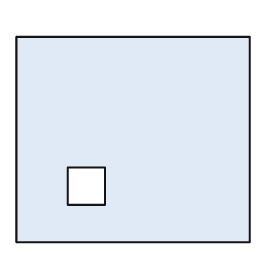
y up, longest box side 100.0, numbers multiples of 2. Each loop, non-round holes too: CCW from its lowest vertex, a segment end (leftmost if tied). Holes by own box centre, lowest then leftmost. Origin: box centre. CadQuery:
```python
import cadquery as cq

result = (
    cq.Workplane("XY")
    .moveTo(-50.0, -44.0)
    .lineTo(50.0, -44.0)
    .lineTo(50.0, 44.0)
    .lineTo(-50.0, 44.0)
    .close()
    .moveTo(-28.0, -28.0)
    .lineTo(-12.0, -28.0)
    .lineTo(-12.0, -12.0)
    .lineTo(-28.0, -12.0)
    .close()
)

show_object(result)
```